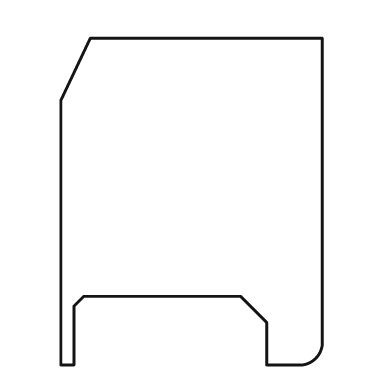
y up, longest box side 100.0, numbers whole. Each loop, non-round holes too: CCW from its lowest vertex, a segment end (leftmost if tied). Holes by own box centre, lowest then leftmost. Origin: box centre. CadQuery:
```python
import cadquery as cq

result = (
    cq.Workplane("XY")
    .moveTo(-40.0, -50.0)
    .lineTo(-36.0, -50.0)
    .lineTo(-36.0, -32.0)
    .lineTo(-33.0, -29.0)
    .lineTo(15.0, -29.0)
    .lineTo(23.0, -37.0)
    .lineTo(23.0, -50.0)
    .lineTo(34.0, -50.0)
    .threePointArc((38.0, -48.0), (40.0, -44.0))
    .lineTo(40.0, 50.0)
    .lineTo(-31.0, 50.0)
    .lineTo(-40.0, 31.0)
    .close()
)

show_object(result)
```